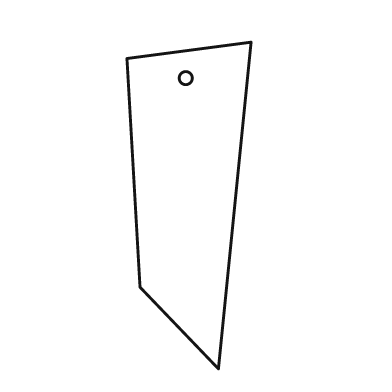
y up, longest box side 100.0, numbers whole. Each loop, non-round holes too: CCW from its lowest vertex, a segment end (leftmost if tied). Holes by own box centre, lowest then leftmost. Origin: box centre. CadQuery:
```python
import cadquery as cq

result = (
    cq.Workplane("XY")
    .moveTo(9.0, -50.0)
    .lineTo(19.0, 50.0)
    .lineTo(-19.0, 45.0)
    .lineTo(-15.0, -25.0)
    .close()
    .moveTo(-1.0, 39.0)
    .circle(2.0)
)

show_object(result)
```